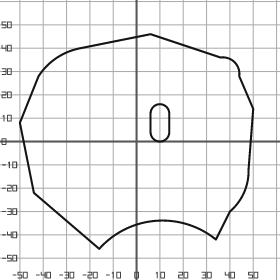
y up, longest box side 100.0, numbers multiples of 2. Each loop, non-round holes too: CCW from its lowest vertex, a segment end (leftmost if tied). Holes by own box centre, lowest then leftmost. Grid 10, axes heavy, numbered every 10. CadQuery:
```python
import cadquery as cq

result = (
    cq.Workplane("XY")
    .moveTo(-16.0, -46.0)
    .threePointArc((8.0, -34.0), (34.0, -42.0))
    .lineTo(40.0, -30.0)
    .threePointArc((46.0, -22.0), (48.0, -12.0))
    .lineTo(50.0, 14.0)
    .lineTo(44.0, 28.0)
    .threePointArc((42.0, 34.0), (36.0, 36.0))
    .lineTo(6.0, 46.0)
    .lineTo(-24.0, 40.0)
    .threePointArc((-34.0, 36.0), (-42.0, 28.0))
    .lineTo(-50.0, 8.0)
    .lineTo(-44.0, -22.0)
    .close()
    .moveTo(6.0, 4.0)
    .threePointArc((10.0, 0.0), (14.0, 4.0))
    .lineTo(14.0, 12.0)
    .threePointArc((10.0, 16.0), (6.0, 12.0))
    .close()
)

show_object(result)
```